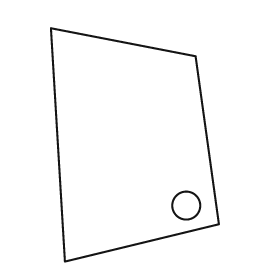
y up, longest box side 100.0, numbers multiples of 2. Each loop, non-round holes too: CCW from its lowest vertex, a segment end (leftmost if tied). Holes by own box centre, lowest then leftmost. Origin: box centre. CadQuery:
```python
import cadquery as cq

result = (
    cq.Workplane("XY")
    .moveTo(-30.0, -50.0)
    .lineTo(36.0, -34.0)
    .lineTo(26.0, 38.0)
    .lineTo(-36.0, 50.0)
    .close()
    .moveTo(22.0, -26.0)
    .circle(6.0)
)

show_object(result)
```